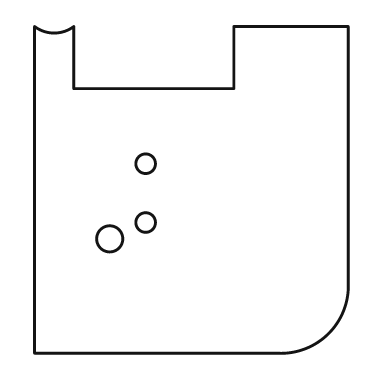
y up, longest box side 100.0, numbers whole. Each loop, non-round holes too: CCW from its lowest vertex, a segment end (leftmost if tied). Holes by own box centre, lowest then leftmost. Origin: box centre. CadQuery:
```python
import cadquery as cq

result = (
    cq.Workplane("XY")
    .moveTo(-48.0, -50.0)
    .lineTo(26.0, -50.0)
    .threePointArc((42.0, -44.0), (48.0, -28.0))
    .lineTo(48.0, 50.0)
    .lineTo(13.0, 50.0)
    .lineTo(13.0, 31.0)
    .lineTo(-36.0, 31.0)
    .lineTo(-36.0, 50.0)
    .threePointArc((-42.0, 48.0), (-48.0, 50.0))
    .close()
    .moveTo(-25.0, -15.0)
    .circle(4.0)
    .moveTo(-14.0, -10.0)
    .circle(3.0)
    .moveTo(-14.0, 8.0)
    .circle(3.0)
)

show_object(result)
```